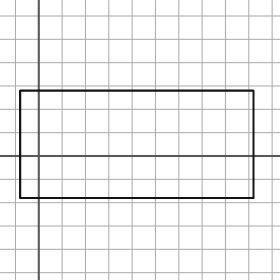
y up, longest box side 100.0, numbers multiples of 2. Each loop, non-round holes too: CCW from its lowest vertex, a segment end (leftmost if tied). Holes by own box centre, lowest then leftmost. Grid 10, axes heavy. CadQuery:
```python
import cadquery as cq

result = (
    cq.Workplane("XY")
    .moveTo(-8.0, -18.0)
    .lineTo(92.0, -18.0)
    .lineTo(92.0, 28.0)
    .lineTo(-8.0, 28.0)
    .close()
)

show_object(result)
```